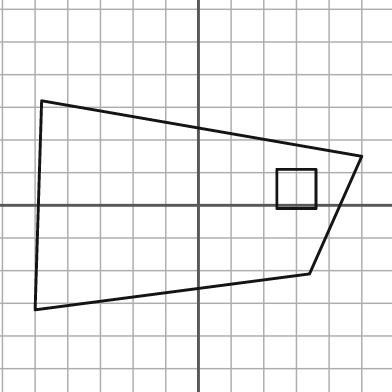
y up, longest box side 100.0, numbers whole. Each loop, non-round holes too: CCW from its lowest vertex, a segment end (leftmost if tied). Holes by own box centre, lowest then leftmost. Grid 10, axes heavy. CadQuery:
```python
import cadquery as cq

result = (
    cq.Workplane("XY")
    .moveTo(-50.0, -32.0)
    .lineTo(34.0, -21.0)
    .lineTo(50.0, 15.0)
    .lineTo(-48.0, 32.0)
    .close()
    .moveTo(24.0, -1.0)
    .lineTo(36.0, -1.0)
    .lineTo(36.0, 11.0)
    .lineTo(24.0, 11.0)
    .close()
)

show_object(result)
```